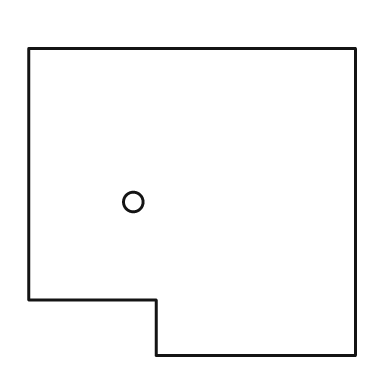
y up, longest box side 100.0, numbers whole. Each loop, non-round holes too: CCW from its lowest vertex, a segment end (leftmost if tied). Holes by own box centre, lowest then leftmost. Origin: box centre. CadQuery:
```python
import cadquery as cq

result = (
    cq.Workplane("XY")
    .moveTo(-11.0, -47.0)
    .lineTo(50.0, -47.0)
    .lineTo(50.0, 47.0)
    .lineTo(-50.0, 47.0)
    .lineTo(-50.0, -30.0)
    .lineTo(-11.0, -30.0)
    .close()
    .moveTo(-18.0, 0.0)
    .circle(3.0)
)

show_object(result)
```